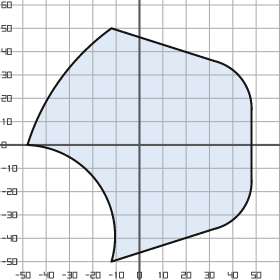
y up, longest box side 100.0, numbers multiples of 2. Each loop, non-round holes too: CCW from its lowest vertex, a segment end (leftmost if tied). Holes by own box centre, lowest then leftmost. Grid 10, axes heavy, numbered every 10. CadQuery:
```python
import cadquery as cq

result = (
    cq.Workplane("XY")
    .moveTo(-12.0, -50.0)
    .lineTo(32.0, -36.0)
    .threePointArc((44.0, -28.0), (48.0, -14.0))
    .lineTo(48.0, 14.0)
    .threePointArc((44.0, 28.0), (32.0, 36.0))
    .lineTo(-12.0, 50.0)
    .threePointArc((-34.0, 28.0), (-48.0, 0.0))
    .threePointArc((-18.0, -16.0), (-12.0, -50.0))
    .close()
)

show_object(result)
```